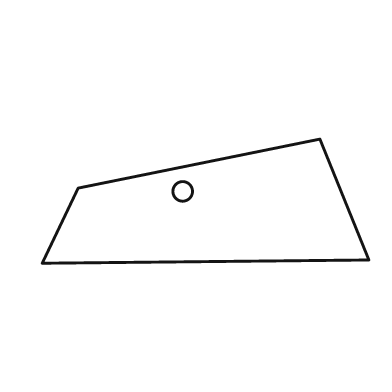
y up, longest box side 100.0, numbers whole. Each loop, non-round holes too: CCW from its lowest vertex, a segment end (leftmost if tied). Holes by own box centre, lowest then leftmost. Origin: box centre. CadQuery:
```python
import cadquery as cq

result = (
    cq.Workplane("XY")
    .moveTo(-50.0, -19.0)
    .lineTo(50.0, -18.0)
    .lineTo(35.0, 19.0)
    .lineTo(-39.0, 4.0)
    .close()
    .moveTo(-7.0, 3.0)
    .circle(3.0)
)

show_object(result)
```